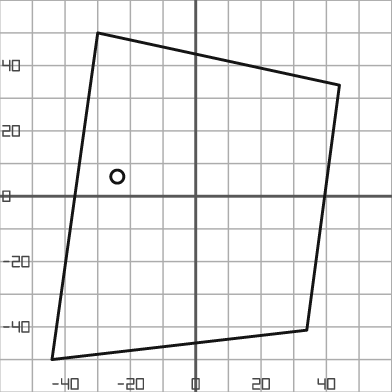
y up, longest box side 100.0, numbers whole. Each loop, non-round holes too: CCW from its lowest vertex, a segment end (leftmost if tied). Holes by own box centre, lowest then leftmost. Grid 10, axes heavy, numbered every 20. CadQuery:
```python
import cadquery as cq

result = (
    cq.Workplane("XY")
    .moveTo(-44.0, -50.0)
    .lineTo(34.0, -41.0)
    .lineTo(44.0, 34.0)
    .lineTo(-30.0, 50.0)
    .close()
    .moveTo(-24.0, 6.0)
    .circle(2.0)
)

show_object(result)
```